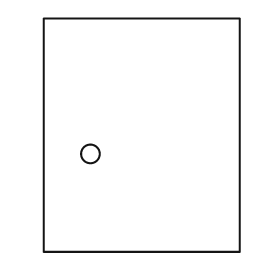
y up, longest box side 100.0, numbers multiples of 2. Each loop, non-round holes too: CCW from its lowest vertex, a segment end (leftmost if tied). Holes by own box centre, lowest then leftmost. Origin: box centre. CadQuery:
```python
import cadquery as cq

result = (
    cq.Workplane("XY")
    .moveTo(-42.0, -50.0)
    .lineTo(42.0, -50.0)
    .lineTo(42.0, 50.0)
    .lineTo(-42.0, 50.0)
    .close()
    .moveTo(-22.0, -8.0)
    .circle(4.0)
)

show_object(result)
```